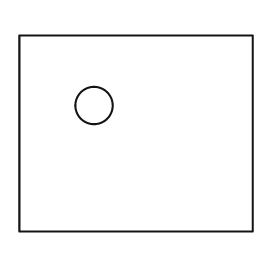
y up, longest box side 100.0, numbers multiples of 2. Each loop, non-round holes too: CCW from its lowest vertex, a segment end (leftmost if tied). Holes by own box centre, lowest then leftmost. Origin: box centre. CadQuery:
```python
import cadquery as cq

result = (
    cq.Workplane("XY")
    .moveTo(-50.0, -42.0)
    .lineTo(50.0, -42.0)
    .lineTo(50.0, 42.0)
    .lineTo(-50.0, 42.0)
    .close()
    .moveTo(-18.0, 12.0)
    .circle(8.0)
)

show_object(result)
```